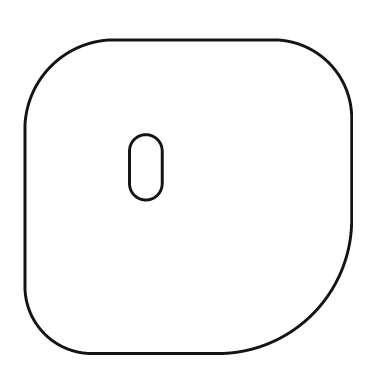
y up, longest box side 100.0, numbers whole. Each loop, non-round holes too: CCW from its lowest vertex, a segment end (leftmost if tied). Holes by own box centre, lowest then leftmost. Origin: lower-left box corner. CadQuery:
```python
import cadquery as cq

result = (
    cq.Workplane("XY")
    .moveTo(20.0, 0.0)
    .lineTo(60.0, 0.0)
    .threePointArc((88.0, 12.0), (100.0, 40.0))
    .lineTo(100.0, 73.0)
    .threePointArc((93.0, 89.0), (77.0, 96.0))
    .lineTo(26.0, 96.0)
    .threePointArc((8.0, 88.0), (0.0, 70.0))
    .lineTo(0.0, 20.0)
    .threePointArc((6.0, 6.0), (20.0, 0.0))
    .close()
    .moveTo(32.0, 52.0)
    .threePointArc((37.0, 47.0), (42.0, 52.0))
    .lineTo(42.0, 62.0)
    .threePointArc((37.0, 67.0), (32.0, 62.0))
    .close()
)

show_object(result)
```